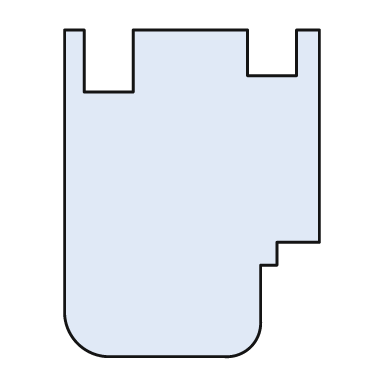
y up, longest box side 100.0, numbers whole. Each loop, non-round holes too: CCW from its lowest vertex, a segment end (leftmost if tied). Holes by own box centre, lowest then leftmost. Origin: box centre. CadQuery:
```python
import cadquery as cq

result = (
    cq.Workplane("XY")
    .moveTo(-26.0, -50.0)
    .lineTo(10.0, -50.0)
    .threePointArc((18.0, -47.0), (21.0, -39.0))
    .lineTo(21.0, -22.0)
    .lineTo(26.0, -22.0)
    .lineTo(26.0, -15.0)
    .lineTo(39.0, -15.0)
    .lineTo(39.0, 50.0)
    .lineTo(32.0, 50.0)
    .lineTo(32.0, 36.0)
    .lineTo(17.0, 36.0)
    .lineTo(17.0, 50.0)
    .lineTo(-18.0, 50.0)
    .lineTo(-18.0, 31.0)
    .lineTo(-33.0, 31.0)
    .lineTo(-33.0, 50.0)
    .lineTo(-39.0, 50.0)
    .lineTo(-39.0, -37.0)
    .threePointArc((-35.0, -46.0), (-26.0, -50.0))
    .close()
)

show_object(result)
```